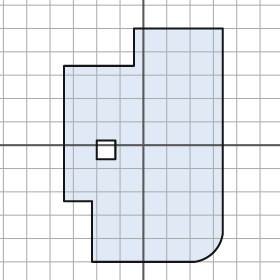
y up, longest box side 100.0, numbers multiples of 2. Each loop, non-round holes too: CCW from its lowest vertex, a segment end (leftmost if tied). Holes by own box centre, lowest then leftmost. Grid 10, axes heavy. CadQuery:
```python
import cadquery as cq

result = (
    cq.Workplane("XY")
    .moveTo(-22.0, -50.0)
    .lineTo(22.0, -50.0)
    .threePointArc((30.0, -46.0), (34.0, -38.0))
    .lineTo(34.0, 50.0)
    .lineTo(-4.0, 50.0)
    .lineTo(-4.0, 34.0)
    .lineTo(-34.0, 34.0)
    .lineTo(-34.0, -24.0)
    .lineTo(-22.0, -24.0)
    .close()
    .moveTo(-20.0, -6.0)
    .lineTo(-12.0, -6.0)
    .lineTo(-12.0, 2.0)
    .lineTo(-20.0, 2.0)
    .close()
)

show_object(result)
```